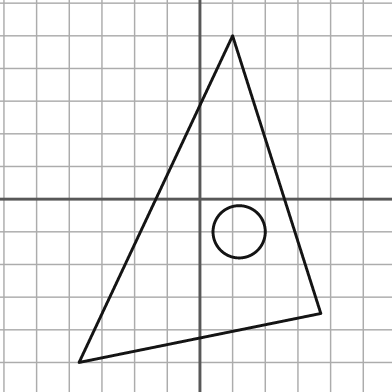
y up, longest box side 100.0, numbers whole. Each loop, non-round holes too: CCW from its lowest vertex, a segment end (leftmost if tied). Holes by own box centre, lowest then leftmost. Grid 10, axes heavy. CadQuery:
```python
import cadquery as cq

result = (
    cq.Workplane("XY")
    .moveTo(-37.0, -50.0)
    .lineTo(37.0, -35.0)
    .lineTo(10.0, 50.0)
    .close()
    .moveTo(12.0, -10.0)
    .circle(8.0)
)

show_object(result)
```